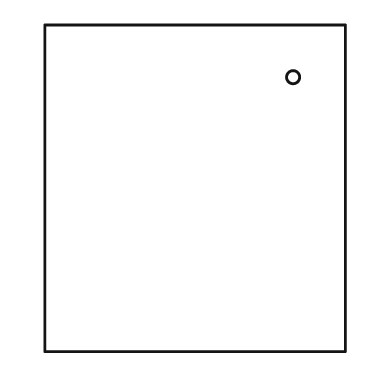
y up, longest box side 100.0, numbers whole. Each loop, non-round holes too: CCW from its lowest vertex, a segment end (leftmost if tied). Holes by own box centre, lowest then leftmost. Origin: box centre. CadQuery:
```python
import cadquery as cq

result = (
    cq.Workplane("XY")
    .moveTo(-46.0, -50.0)
    .lineTo(46.0, -50.0)
    .lineTo(46.0, 50.0)
    .lineTo(-46.0, 50.0)
    .close()
    .moveTo(30.0, 34.0)
    .circle(2.0)
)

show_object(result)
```